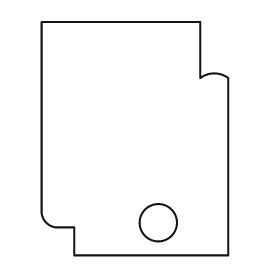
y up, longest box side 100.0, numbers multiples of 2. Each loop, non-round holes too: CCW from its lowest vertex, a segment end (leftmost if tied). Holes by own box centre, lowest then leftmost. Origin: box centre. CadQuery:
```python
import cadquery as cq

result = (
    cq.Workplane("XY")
    .moveTo(-26.0, -50.0)
    .lineTo(40.0, -50.0)
    .lineTo(40.0, 26.0)
    .threePointArc((34.0, 28.0), (28.0, 26.0))
    .lineTo(28.0, 50.0)
    .lineTo(-40.0, 50.0)
    .lineTo(-40.0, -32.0)
    .threePointArc((-38.0, -36.0), (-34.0, -38.0))
    .lineTo(-26.0, -38.0)
    .close()
    .moveTo(10.0, -36.0)
    .circle(8.0)
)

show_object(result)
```